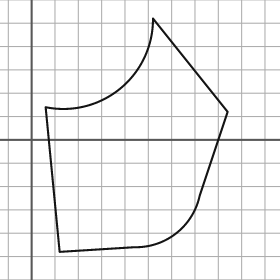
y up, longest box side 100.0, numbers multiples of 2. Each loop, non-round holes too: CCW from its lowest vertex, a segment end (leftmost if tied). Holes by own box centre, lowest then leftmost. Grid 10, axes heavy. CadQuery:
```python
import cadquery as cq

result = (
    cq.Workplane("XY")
    .moveTo(12.0, -48.0)
    .lineTo(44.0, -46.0)
    .threePointArc((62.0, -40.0), (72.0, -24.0))
    .lineTo(84.0, 12.0)
    .lineTo(52.0, 52.0)
    .threePointArc((38.0, 22.0), (6.0, 14.0))
    .close()
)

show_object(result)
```